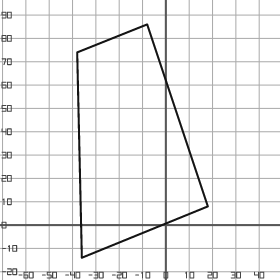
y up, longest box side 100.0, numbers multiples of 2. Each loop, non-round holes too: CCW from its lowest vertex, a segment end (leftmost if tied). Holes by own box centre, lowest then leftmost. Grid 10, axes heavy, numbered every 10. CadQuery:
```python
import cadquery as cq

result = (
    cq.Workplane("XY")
    .moveTo(-36.0, -14.0)
    .lineTo(18.0, 8.0)
    .lineTo(-8.0, 86.0)
    .lineTo(-38.0, 74.0)
    .close()
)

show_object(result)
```